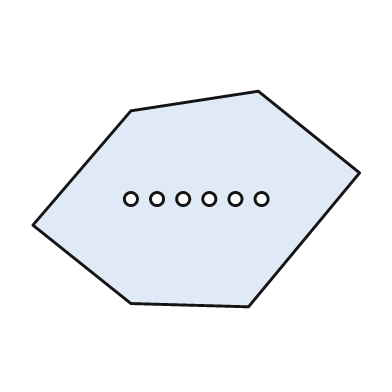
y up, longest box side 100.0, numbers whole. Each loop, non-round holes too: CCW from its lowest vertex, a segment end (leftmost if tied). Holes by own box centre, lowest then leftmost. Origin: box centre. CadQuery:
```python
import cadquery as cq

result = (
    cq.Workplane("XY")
    .moveTo(16.0, -33.0)
    .lineTo(50.0, 8.0)
    .lineTo(19.0, 33.0)
    .lineTo(-20.0, 27.0)
    .lineTo(-50.0, -8.0)
    .lineTo(-20.0, -32.0)
    .close()
    .moveTo(-20.0, 0.0)
    .circle(2.0)
    .moveTo(-12.0, 0.0)
    .circle(2.0)
    .moveTo(-4.0, 0.0)
    .circle(2.0)
    .moveTo(4.0, 0.0)
    .circle(2.0)
    .moveTo(12.0, 0.0)
    .circle(2.0)
    .moveTo(20.0, 0.0)
    .circle(2.0)
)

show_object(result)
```